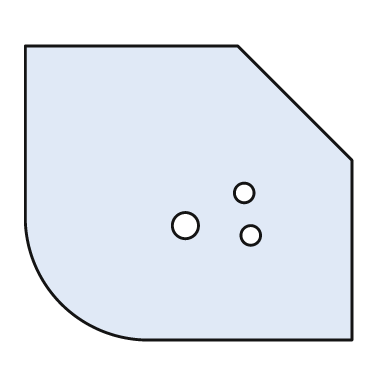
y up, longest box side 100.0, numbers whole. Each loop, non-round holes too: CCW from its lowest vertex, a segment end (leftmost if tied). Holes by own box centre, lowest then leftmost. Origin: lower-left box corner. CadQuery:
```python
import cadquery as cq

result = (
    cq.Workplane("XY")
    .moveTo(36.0, 0.0)
    .lineTo(100.0, 0.0)
    .lineTo(100.0, 55.0)
    .lineTo(65.0, 90.0)
    .lineTo(0.0, 90.0)
    .lineTo(0.0, 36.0)
    .threePointArc((11.0, 11.0), (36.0, 0.0))
    .close()
    .moveTo(69.0, 32.0)
    .circle(3.0)
    .moveTo(49.0, 35.0)
    .circle(4.0)
    .moveTo(67.0, 45.0)
    .circle(3.0)
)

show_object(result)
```